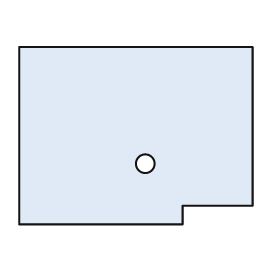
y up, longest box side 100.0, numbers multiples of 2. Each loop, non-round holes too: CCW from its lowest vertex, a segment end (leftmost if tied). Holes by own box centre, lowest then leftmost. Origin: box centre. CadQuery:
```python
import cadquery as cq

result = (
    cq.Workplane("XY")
    .moveTo(-50.0, -38.0)
    .lineTo(20.0, -38.0)
    .lineTo(20.0, -30.0)
    .lineTo(50.0, -30.0)
    .lineTo(50.0, 38.0)
    .lineTo(-50.0, 38.0)
    .close()
    .moveTo(4.0, -12.0)
    .circle(4.0)
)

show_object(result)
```